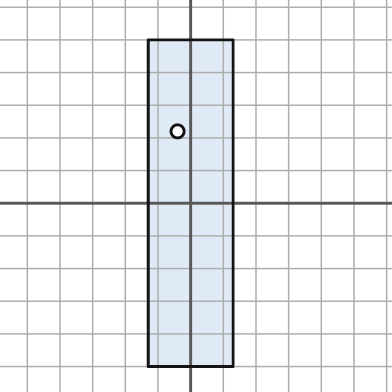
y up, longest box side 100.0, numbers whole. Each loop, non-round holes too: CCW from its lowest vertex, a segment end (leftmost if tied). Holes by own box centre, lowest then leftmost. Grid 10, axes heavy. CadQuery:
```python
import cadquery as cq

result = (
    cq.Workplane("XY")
    .moveTo(-13.0, -50.0)
    .lineTo(13.0, -50.0)
    .lineTo(13.0, 50.0)
    .lineTo(-13.0, 50.0)
    .close()
    .moveTo(-4.0, 22.0)
    .circle(2.0)
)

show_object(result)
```